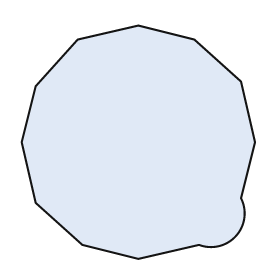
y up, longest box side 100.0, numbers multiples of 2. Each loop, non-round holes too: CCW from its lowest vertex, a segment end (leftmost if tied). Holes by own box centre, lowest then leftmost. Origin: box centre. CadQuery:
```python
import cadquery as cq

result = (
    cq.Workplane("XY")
    .moveTo(0.0, -50.0)
    .lineTo(26.0, -44.0)
    .threePointArc((42.0, -40.0), (44.0, -24.0))
    .lineTo(50.0, 0.0)
    .lineTo(44.0, 26.0)
    .lineTo(24.0, 44.0)
    .lineTo(0.0, 50.0)
    .lineTo(-26.0, 44.0)
    .lineTo(-44.0, 24.0)
    .lineTo(-50.0, 0.0)
    .lineTo(-44.0, -26.0)
    .lineTo(-24.0, -44.0)
    .close()
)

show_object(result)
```